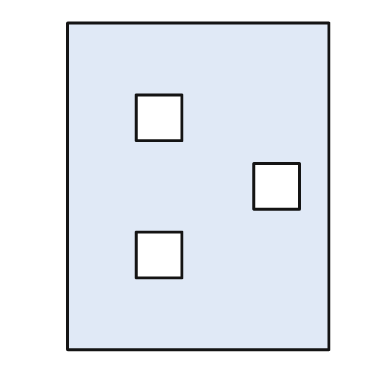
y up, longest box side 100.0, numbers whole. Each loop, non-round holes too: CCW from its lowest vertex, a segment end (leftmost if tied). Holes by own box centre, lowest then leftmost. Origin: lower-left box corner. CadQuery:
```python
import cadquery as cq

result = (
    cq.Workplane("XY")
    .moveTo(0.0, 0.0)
    .lineTo(80.0, 0.0)
    .lineTo(80.0, 100.0)
    .lineTo(0.0, 100.0)
    .close()
    .moveTo(21.0, 22.0)
    .lineTo(35.0, 22.0)
    .lineTo(35.0, 36.0)
    .lineTo(21.0, 36.0)
    .close()
    .moveTo(57.0, 43.0)
    .lineTo(71.0, 43.0)
    .lineTo(71.0, 57.0)
    .lineTo(57.0, 57.0)
    .close()
    .moveTo(21.0, 64.0)
    .lineTo(35.0, 64.0)
    .lineTo(35.0, 78.0)
    .lineTo(21.0, 78.0)
    .close()
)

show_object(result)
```